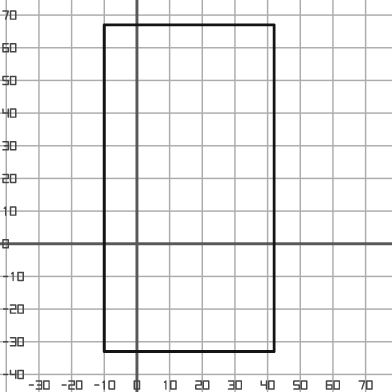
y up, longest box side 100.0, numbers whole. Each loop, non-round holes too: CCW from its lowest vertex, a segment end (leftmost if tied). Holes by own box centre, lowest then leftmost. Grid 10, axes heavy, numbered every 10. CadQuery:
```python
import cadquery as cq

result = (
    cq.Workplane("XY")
    .moveTo(-10.0, -33.0)
    .lineTo(42.0, -33.0)
    .lineTo(42.0, 67.0)
    .lineTo(-10.0, 67.0)
    .close()
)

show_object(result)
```